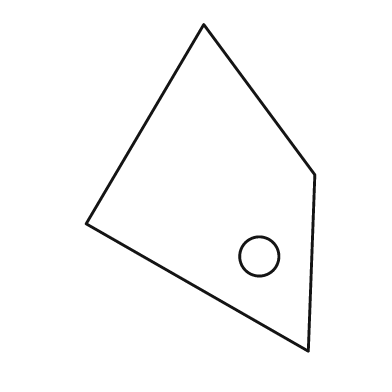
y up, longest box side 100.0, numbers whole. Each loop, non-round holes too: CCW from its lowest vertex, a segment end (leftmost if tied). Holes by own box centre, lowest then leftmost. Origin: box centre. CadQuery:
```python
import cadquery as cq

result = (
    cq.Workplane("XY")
    .moveTo(33.0, -50.0)
    .lineTo(35.0, 4.0)
    .lineTo(1.0, 50.0)
    .lineTo(-35.0, -11.0)
    .close()
    .moveTo(18.0, -21.0)
    .circle(6.0)
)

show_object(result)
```